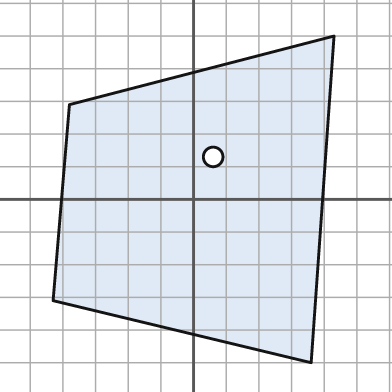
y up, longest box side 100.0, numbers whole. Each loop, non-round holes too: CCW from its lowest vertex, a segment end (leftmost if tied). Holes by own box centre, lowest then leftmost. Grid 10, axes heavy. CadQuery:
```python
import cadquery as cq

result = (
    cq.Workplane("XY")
    .moveTo(36.0, -50.0)
    .lineTo(43.0, 50.0)
    .lineTo(-38.0, 29.0)
    .lineTo(-43.0, -31.0)
    .close()
    .moveTo(6.0, 13.0)
    .circle(3.0)
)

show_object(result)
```